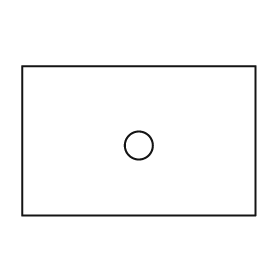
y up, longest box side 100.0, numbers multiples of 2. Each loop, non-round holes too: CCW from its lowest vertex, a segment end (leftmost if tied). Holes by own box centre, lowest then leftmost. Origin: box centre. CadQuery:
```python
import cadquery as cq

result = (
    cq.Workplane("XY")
    .moveTo(-50.0, -32.0)
    .lineTo(50.0, -32.0)
    .lineTo(50.0, 32.0)
    .lineTo(-50.0, 32.0)
    .close()
    .moveTo(0.0, -2.0)
    .circle(6.0)
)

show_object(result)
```